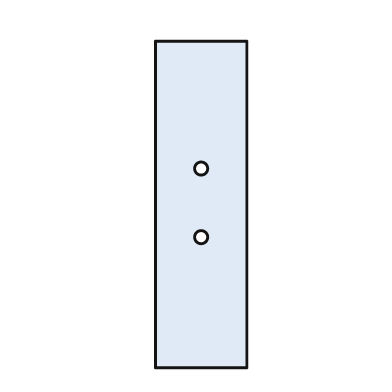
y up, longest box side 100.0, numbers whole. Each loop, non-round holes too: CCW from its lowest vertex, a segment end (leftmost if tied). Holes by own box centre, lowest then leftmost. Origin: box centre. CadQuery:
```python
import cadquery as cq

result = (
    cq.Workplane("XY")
    .moveTo(-14.0, -50.0)
    .lineTo(14.0, -50.0)
    .lineTo(14.0, 50.0)
    .lineTo(-14.0, 50.0)
    .close()
    .moveTo(0.0, -10.0)
    .circle(2.0)
    .moveTo(0.0, 11.0)
    .circle(2.0)
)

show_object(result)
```